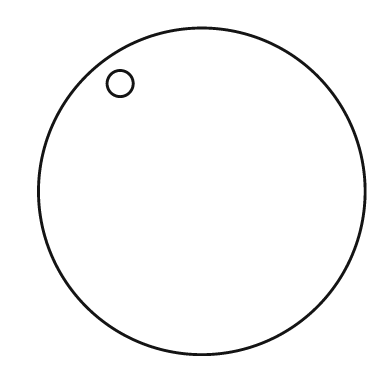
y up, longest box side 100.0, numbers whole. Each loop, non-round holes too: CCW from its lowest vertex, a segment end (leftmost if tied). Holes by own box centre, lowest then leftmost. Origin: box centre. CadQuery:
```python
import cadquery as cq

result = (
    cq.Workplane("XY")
    .moveTo(0.0, 0.0)
    .circle(50.0)
    .moveTo(-25.0, 33.0)
    .circle(4.0)
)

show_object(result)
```